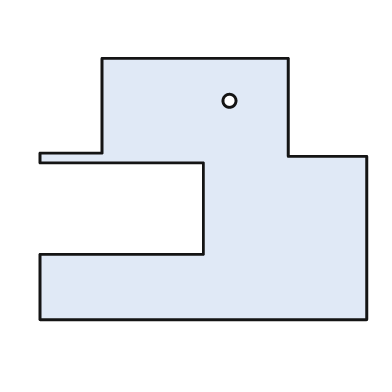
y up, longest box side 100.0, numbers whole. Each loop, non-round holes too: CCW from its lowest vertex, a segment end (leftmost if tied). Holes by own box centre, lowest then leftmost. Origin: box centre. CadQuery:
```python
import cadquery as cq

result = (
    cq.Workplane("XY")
    .moveTo(-50.0, -40.0)
    .lineTo(50.0, -40.0)
    .lineTo(50.0, 10.0)
    .lineTo(26.0, 10.0)
    .lineTo(26.0, 40.0)
    .lineTo(-31.0, 40.0)
    .lineTo(-31.0, 11.0)
    .lineTo(-50.0, 11.0)
    .lineTo(-50.0, 8.0)
    .lineTo(0.0, 8.0)
    .lineTo(0.0, -20.0)
    .lineTo(-50.0, -20.0)
    .close()
    .moveTo(8.0, 27.0)
    .circle(2.0)
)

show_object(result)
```